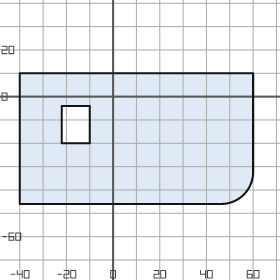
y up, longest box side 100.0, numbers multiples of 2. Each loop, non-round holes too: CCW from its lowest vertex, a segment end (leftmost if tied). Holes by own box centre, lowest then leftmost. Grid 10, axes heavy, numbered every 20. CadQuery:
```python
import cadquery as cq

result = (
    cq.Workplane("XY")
    .moveTo(-40.0, -46.0)
    .lineTo(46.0, -46.0)
    .threePointArc((56.0, -42.0), (60.0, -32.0))
    .lineTo(60.0, 10.0)
    .lineTo(-40.0, 10.0)
    .close()
    .moveTo(-22.0, -20.0)
    .lineTo(-10.0, -20.0)
    .lineTo(-10.0, -4.0)
    .lineTo(-22.0, -4.0)
    .close()
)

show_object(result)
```